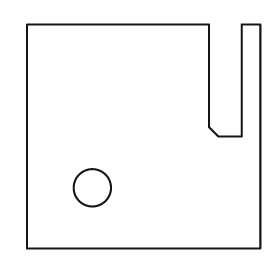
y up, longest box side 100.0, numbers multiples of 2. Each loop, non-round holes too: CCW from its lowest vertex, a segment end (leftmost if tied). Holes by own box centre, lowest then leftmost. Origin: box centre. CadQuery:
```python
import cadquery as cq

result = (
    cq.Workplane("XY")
    .moveTo(-50.0, -48.0)
    .lineTo(50.0, -48.0)
    .lineTo(50.0, 48.0)
    .lineTo(42.0, 48.0)
    .lineTo(42.0, 0.0)
    .lineTo(32.0, 0.0)
    .lineTo(28.0, 4.0)
    .lineTo(28.0, 48.0)
    .lineTo(-50.0, 48.0)
    .close()
    .moveTo(-22.0, -22.0)
    .circle(8.0)
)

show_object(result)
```